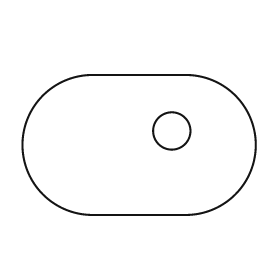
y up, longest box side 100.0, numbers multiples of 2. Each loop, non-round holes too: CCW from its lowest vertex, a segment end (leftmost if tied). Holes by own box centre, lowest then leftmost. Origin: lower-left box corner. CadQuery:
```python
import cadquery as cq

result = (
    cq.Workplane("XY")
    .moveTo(30.0, 0.0)
    .lineTo(70.0, 0.0)
    .threePointArc((100.0, 30.0), (70.0, 60.0))
    .lineTo(30.0, 60.0)
    .threePointArc((0.0, 30.0), (30.0, 0.0))
    .close()
    .moveTo(64.0, 36.0)
    .circle(8.0)
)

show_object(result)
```